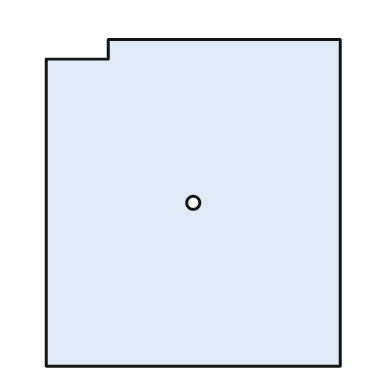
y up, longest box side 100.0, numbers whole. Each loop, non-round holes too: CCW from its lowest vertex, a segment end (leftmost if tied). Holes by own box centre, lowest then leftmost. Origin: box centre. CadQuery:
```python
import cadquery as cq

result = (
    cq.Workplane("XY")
    .moveTo(-45.0, -50.0)
    .lineTo(45.0, -50.0)
    .lineTo(45.0, 50.0)
    .lineTo(-26.0, 50.0)
    .lineTo(-26.0, 44.0)
    .lineTo(-45.0, 44.0)
    .close()
    .moveTo(0.0, 0.0)
    .circle(2.0)
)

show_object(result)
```